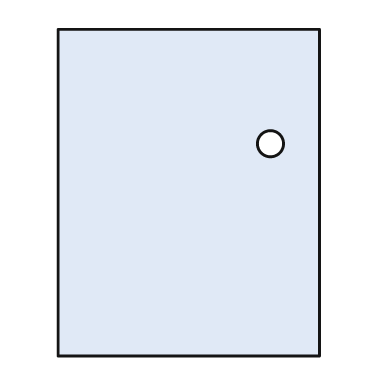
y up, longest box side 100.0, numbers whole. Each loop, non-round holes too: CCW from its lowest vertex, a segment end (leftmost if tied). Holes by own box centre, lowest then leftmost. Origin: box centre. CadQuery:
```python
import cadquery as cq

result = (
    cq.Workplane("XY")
    .moveTo(-40.0, -50.0)
    .lineTo(40.0, -50.0)
    .lineTo(40.0, 50.0)
    .lineTo(-40.0, 50.0)
    .close()
    .moveTo(25.0, 15.0)
    .circle(4.0)
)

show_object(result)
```